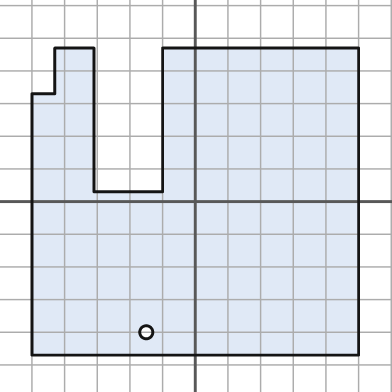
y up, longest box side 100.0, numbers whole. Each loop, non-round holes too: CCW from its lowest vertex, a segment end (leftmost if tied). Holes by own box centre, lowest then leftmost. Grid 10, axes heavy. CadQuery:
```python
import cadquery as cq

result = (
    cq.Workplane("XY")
    .moveTo(-50.0, -47.0)
    .lineTo(50.0, -47.0)
    .lineTo(50.0, 47.0)
    .lineTo(-10.0, 47.0)
    .lineTo(-10.0, 3.0)
    .lineTo(-31.0, 3.0)
    .lineTo(-31.0, 47.0)
    .lineTo(-43.0, 47.0)
    .lineTo(-43.0, 33.0)
    .lineTo(-50.0, 33.0)
    .close()
    .moveTo(-15.0, -40.0)
    .circle(2.0)
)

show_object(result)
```